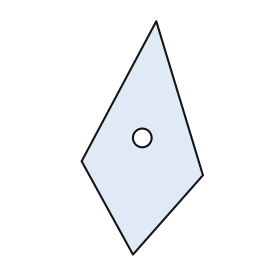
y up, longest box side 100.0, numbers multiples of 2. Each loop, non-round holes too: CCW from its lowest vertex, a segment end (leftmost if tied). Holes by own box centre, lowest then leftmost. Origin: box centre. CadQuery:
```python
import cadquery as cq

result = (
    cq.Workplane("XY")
    .moveTo(-4.0, -50.0)
    .lineTo(26.0, -16.0)
    .lineTo(6.0, 50.0)
    .lineTo(-26.0, -10.0)
    .close()
    .moveTo(0.0, 0.0)
    .circle(4.0)
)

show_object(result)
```